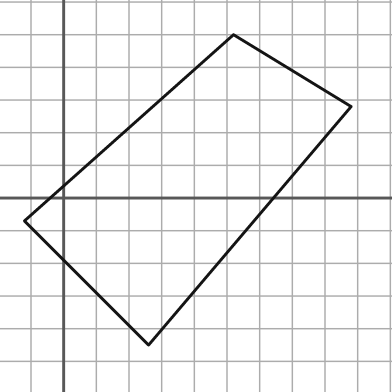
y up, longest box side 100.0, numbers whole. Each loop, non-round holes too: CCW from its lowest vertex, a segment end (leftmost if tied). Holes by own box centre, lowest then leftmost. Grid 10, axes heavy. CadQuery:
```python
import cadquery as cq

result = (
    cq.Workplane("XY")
    .moveTo(26.0, -45.0)
    .lineTo(88.0, 28.0)
    .lineTo(52.0, 50.0)
    .lineTo(-12.0, -7.0)
    .close()
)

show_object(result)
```